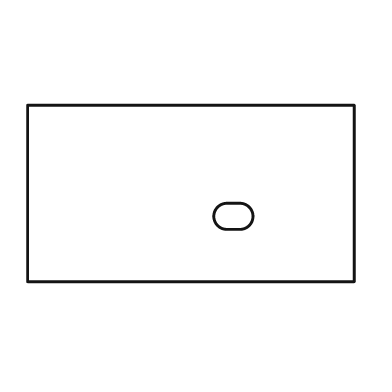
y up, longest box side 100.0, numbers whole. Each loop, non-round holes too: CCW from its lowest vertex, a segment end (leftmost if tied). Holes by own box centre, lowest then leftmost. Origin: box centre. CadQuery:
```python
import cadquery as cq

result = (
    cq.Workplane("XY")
    .moveTo(-50.0, -27.0)
    .lineTo(50.0, -27.0)
    .lineTo(50.0, 27.0)
    .lineTo(-50.0, 27.0)
    .close()
    .moveTo(11.0, -11.0)
    .lineTo(15.0, -11.0)
    .threePointArc((19.0, -7.0), (15.0, -3.0))
    .lineTo(11.0, -3.0)
    .threePointArc((7.0, -7.0), (11.0, -11.0))
    .close()
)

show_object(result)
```